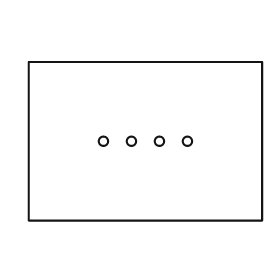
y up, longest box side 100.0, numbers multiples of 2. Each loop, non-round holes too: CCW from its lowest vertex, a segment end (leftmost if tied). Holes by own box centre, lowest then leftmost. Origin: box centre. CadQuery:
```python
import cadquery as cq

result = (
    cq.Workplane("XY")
    .moveTo(-50.0, -34.0)
    .lineTo(50.0, -34.0)
    .lineTo(50.0, 34.0)
    .lineTo(-50.0, 34.0)
    .close()
    .moveTo(-18.0, 0.0)
    .circle(2.0)
    .moveTo(-6.0, 0.0)
    .circle(2.0)
    .moveTo(6.0, 0.0)
    .circle(2.0)
    .moveTo(18.0, 0.0)
    .circle(2.0)
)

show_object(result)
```